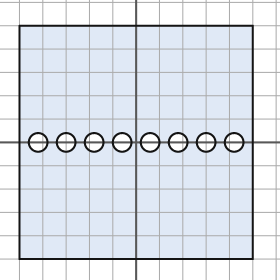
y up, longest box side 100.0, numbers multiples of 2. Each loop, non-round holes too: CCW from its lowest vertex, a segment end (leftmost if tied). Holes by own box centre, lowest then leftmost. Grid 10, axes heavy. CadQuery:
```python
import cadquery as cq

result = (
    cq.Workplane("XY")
    .moveTo(-50.0, -50.0)
    .lineTo(50.0, -50.0)
    .lineTo(50.0, 50.0)
    .lineTo(-50.0, 50.0)
    .close()
    .moveTo(-42.0, 0.0)
    .circle(4.0)
    .moveTo(-30.0, 0.0)
    .circle(4.0)
    .moveTo(-18.0, 0.0)
    .circle(4.0)
    .moveTo(-6.0, 0.0)
    .circle(4.0)
    .moveTo(6.0, 0.0)
    .circle(4.0)
    .moveTo(18.0, 0.0)
    .circle(4.0)
    .moveTo(30.0, 0.0)
    .circle(4.0)
    .moveTo(42.0, 0.0)
    .circle(4.0)
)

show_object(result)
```